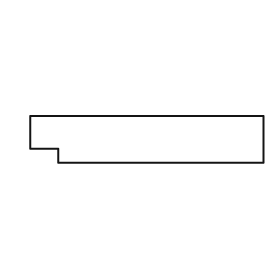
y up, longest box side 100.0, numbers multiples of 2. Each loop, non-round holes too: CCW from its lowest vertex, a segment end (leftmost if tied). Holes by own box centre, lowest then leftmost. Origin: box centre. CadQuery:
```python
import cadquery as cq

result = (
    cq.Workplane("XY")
    .moveTo(-38.0, -10.0)
    .lineTo(50.0, -10.0)
    .lineTo(50.0, 10.0)
    .lineTo(-50.0, 10.0)
    .lineTo(-50.0, -4.0)
    .lineTo(-38.0, -4.0)
    .close()
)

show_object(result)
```